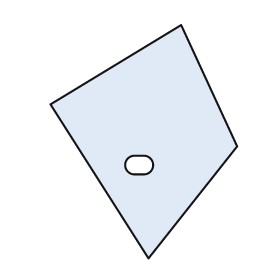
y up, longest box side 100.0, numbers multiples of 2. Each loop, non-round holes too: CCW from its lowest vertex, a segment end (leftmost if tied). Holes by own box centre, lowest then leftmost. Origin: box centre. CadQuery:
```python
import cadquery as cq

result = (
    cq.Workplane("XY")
    .moveTo(2.0, -50.0)
    .lineTo(40.0, -2.0)
    .lineTo(16.0, 50.0)
    .lineTo(-40.0, 16.0)
    .close()
    .moveTo(-4.0, -14.0)
    .lineTo(0.0, -14.0)
    .threePointArc((4.0, -10.0), (0.0, -6.0))
    .lineTo(-4.0, -6.0)
    .threePointArc((-8.0, -10.0), (-4.0, -14.0))
    .close()
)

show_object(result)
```